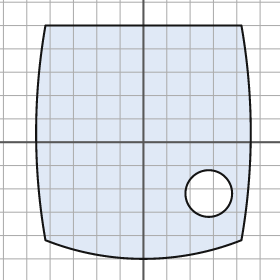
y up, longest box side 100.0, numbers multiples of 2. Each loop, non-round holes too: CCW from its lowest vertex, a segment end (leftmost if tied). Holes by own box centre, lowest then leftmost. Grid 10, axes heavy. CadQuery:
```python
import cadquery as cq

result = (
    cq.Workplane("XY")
    .moveTo(-42.0, -42.0)
    .threePointArc((0.0, -50.0), (42.0, -42.0))
    .threePointArc((46.0, 4.0), (42.0, 50.0))
    .lineTo(-42.0, 50.0)
    .threePointArc((-46.0, 4.0), (-42.0, -42.0))
    .close()
    .moveTo(28.0, -22.0)
    .circle(10.0)
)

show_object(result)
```